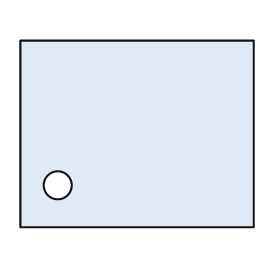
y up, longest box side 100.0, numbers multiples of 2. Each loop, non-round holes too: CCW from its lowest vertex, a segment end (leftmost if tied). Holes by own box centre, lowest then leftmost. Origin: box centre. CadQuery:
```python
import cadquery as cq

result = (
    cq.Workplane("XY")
    .moveTo(-50.0, -40.0)
    .lineTo(50.0, -40.0)
    .lineTo(50.0, 40.0)
    .lineTo(-50.0, 40.0)
    .close()
    .moveTo(-34.0, -22.0)
    .circle(6.0)
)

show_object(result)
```